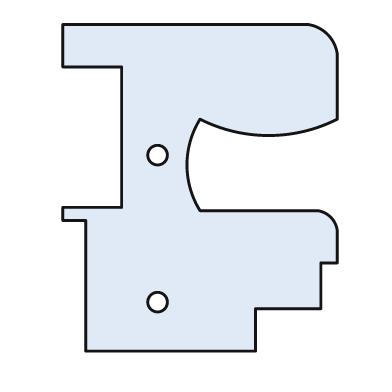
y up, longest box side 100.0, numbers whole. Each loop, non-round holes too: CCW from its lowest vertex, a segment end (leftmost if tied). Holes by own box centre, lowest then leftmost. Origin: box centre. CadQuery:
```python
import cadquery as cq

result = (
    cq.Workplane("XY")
    .moveTo(-35.0, -50.0)
    .lineTo(17.0, -50.0)
    .lineTo(17.0, -37.0)
    .lineTo(37.0, -37.0)
    .lineTo(37.0, -23.0)
    .lineTo(42.0, -23.0)
    .lineTo(42.0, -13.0)
    .threePointArc((40.0, -9.0), (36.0, -7.0))
    .lineTo(0.0, -7.0)
    .threePointArc((-4.0, 7.0), (0.0, 21.0))
    .threePointArc((21.0, 16.0), (42.0, 21.0))
    .lineTo(42.0, 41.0)
    .threePointArc((39.0, 47.0), (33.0, 50.0))
    .lineTo(-42.0, 50.0)
    .lineTo(-42.0, 37.0)
    .lineTo(-24.0, 37.0)
    .lineTo(-24.0, -6.0)
    .lineTo(-42.0, -6.0)
    .lineTo(-42.0, -10.0)
    .lineTo(-35.0, -10.0)
    .close()
    .moveTo(-13.0, -35.0)
    .circle(3.0)
    .moveTo(-13.0, 10.0)
    .circle(3.0)
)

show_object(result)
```